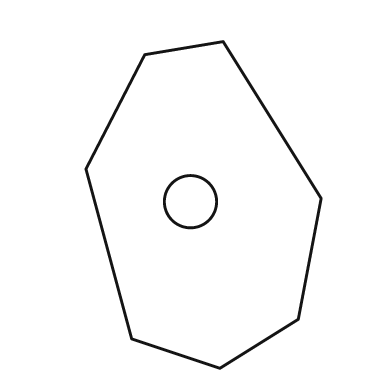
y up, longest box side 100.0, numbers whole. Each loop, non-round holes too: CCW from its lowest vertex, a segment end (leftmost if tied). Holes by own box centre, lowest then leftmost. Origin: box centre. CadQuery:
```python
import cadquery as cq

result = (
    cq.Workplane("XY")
    .moveTo(5.0, -50.0)
    .lineTo(29.0, -35.0)
    .lineTo(36.0, 2.0)
    .lineTo(6.0, 50.0)
    .lineTo(-18.0, 46.0)
    .lineTo(-36.0, 11.0)
    .lineTo(-22.0, -41.0)
    .close()
    .moveTo(-4.0, 1.0)
    .circle(8.0)
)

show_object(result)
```